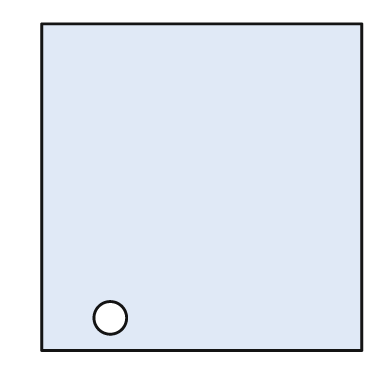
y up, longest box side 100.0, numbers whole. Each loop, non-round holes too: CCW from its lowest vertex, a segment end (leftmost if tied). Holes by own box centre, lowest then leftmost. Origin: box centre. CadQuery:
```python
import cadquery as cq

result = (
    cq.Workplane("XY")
    .moveTo(-49.0, -50.0)
    .lineTo(49.0, -50.0)
    .lineTo(49.0, 50.0)
    .lineTo(-49.0, 50.0)
    .close()
    .moveTo(-28.0, -40.0)
    .circle(5.0)
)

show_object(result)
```